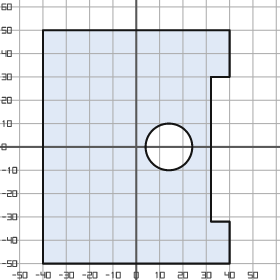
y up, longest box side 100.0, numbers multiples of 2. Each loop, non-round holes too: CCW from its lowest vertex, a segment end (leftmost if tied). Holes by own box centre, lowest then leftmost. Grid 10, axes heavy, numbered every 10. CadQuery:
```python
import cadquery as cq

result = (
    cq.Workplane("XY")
    .moveTo(-40.0, -50.0)
    .lineTo(40.0, -50.0)
    .lineTo(40.0, -32.0)
    .lineTo(32.0, -32.0)
    .lineTo(32.0, 30.0)
    .lineTo(40.0, 30.0)
    .lineTo(40.0, 50.0)
    .lineTo(-40.0, 50.0)
    .close()
    .moveTo(14.0, 0.0)
    .circle(10.0)
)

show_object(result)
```